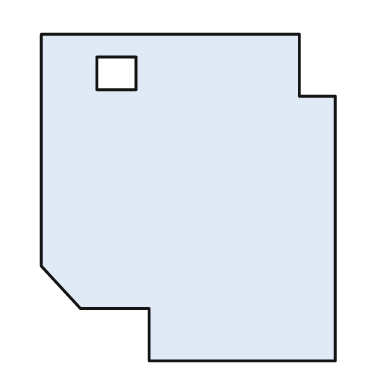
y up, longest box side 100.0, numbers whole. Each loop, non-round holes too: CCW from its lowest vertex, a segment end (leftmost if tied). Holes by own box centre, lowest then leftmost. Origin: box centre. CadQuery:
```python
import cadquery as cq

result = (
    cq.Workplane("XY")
    .moveTo(-12.0, -50.0)
    .lineTo(45.0, -50.0)
    .lineTo(45.0, 31.0)
    .lineTo(34.0, 31.0)
    .lineTo(34.0, 50.0)
    .lineTo(-45.0, 50.0)
    .lineTo(-45.0, -21.0)
    .lineTo(-33.0, -34.0)
    .lineTo(-12.0, -34.0)
    .close()
    .moveTo(-28.0, 33.0)
    .lineTo(-16.0, 33.0)
    .lineTo(-16.0, 43.0)
    .lineTo(-28.0, 43.0)
    .close()
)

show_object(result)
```